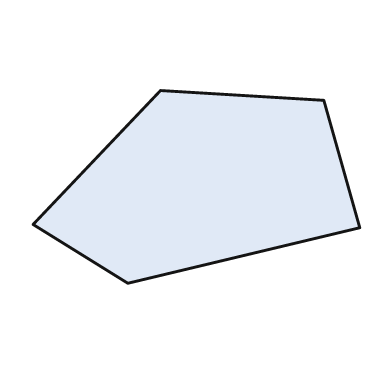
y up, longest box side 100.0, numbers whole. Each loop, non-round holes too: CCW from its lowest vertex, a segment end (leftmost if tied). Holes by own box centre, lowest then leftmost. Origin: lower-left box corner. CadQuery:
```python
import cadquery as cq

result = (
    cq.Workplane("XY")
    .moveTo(29.0, 0.0)
    .lineTo(100.0, 17.0)
    .lineTo(89.0, 56.0)
    .lineTo(39.0, 59.0)
    .lineTo(0.0, 18.0)
    .close()
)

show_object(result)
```